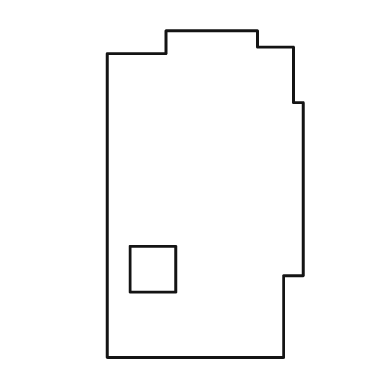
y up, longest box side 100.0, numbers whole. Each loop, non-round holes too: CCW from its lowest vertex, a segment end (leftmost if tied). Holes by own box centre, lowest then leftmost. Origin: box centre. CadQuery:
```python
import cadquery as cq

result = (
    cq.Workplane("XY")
    .moveTo(-30.0, -50.0)
    .lineTo(24.0, -50.0)
    .lineTo(24.0, -25.0)
    .lineTo(30.0, -25.0)
    .lineTo(30.0, 28.0)
    .lineTo(27.0, 28.0)
    .lineTo(27.0, 45.0)
    .lineTo(16.0, 45.0)
    .lineTo(16.0, 50.0)
    .lineTo(-12.0, 50.0)
    .lineTo(-12.0, 43.0)
    .lineTo(-30.0, 43.0)
    .close()
    .moveTo(-23.0, -30.0)
    .lineTo(-9.0, -30.0)
    .lineTo(-9.0, -16.0)
    .lineTo(-23.0, -16.0)
    .close()
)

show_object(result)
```